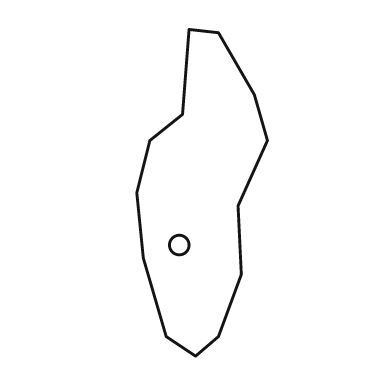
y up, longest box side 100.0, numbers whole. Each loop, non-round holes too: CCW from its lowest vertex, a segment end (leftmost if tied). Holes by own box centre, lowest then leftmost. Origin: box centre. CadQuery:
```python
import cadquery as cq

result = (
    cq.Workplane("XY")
    .moveTo(-2.0, -50.0)
    .lineTo(5.0, -44.0)
    .lineTo(12.0, -25.0)
    .lineTo(11.0, -4.0)
    .lineTo(20.0, 16.0)
    .lineTo(16.0, 30.0)
    .lineTo(5.0, 49.0)
    .lineTo(-4.0, 50.0)
    .lineTo(-6.0, 24.0)
    .lineTo(-16.0, 16.0)
    .lineTo(-20.0, 0.0)
    .lineTo(-18.0, -20.0)
    .lineTo(-11.0, -44.0)
    .close()
    .moveTo(-7.0, -16.0)
    .circle(3.0)
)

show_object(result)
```